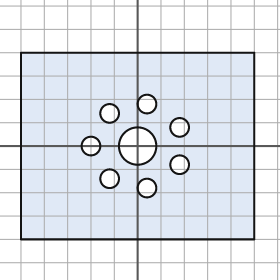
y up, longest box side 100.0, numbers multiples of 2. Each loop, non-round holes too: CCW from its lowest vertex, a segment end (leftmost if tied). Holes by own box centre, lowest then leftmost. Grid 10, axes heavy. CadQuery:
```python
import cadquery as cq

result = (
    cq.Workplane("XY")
    .moveTo(-50.0, -40.0)
    .lineTo(50.0, -40.0)
    .lineTo(50.0, 40.0)
    .lineTo(-50.0, 40.0)
    .close()
    .moveTo(4.0, -18.0)
    .circle(4.0)
    .moveTo(-12.0, -14.0)
    .circle(4.0)
    .moveTo(18.0, -8.0)
    .circle(4.0)
    .moveTo(-20.0, 0.0)
    .circle(4.0)
    .moveTo(0.0, 0.0)
    .circle(8.0)
    .moveTo(18.0, 8.0)
    .circle(4.0)
    .moveTo(-12.0, 14.0)
    .circle(4.0)
    .moveTo(4.0, 18.0)
    .circle(4.0)
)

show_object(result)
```